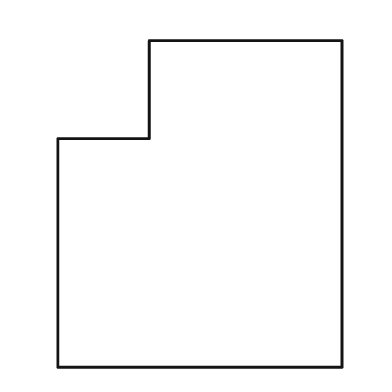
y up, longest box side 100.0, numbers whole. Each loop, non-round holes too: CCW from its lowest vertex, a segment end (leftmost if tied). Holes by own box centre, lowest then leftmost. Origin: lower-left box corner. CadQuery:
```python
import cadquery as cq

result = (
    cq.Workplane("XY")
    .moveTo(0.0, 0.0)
    .lineTo(87.0, 0.0)
    .lineTo(87.0, 100.0)
    .lineTo(28.0, 100.0)
    .lineTo(28.0, 70.0)
    .lineTo(0.0, 70.0)
    .close()
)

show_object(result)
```